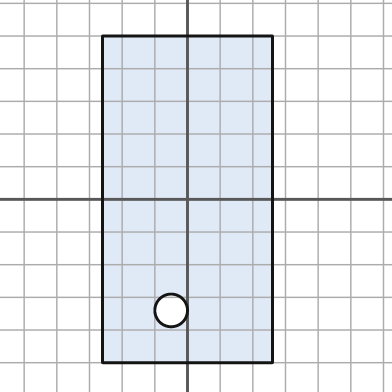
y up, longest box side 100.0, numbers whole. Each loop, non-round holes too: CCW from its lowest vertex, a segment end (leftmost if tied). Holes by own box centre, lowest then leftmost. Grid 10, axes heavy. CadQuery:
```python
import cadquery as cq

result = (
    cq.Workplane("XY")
    .moveTo(-26.0, -50.0)
    .lineTo(26.0, -50.0)
    .lineTo(26.0, 50.0)
    .lineTo(-26.0, 50.0)
    .close()
    .moveTo(-5.0, -34.0)
    .circle(5.0)
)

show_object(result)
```